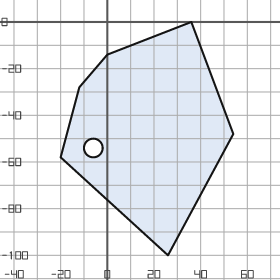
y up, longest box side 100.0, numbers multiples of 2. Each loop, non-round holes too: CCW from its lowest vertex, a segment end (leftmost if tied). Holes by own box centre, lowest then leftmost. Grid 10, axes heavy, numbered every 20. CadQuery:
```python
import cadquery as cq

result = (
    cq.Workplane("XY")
    .moveTo(26.0, -100.0)
    .lineTo(54.0, -48.0)
    .lineTo(36.0, 0.0)
    .lineTo(0.0, -14.0)
    .lineTo(-12.0, -28.0)
    .lineTo(-20.0, -58.0)
    .close()
    .moveTo(-6.0, -54.0)
    .circle(4.0)
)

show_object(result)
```